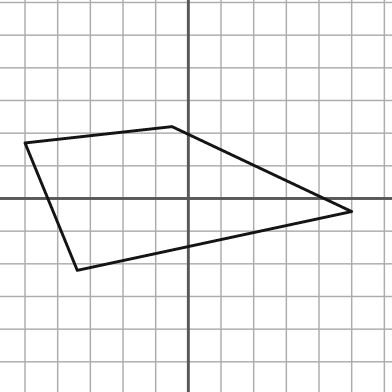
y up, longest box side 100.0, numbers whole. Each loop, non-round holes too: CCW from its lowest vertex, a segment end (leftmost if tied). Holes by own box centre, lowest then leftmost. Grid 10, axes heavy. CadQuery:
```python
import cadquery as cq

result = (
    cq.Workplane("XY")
    .moveTo(-34.0, -22.0)
    .lineTo(50.0, -4.0)
    .lineTo(-5.0, 22.0)
    .lineTo(-50.0, 17.0)
    .close()
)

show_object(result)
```